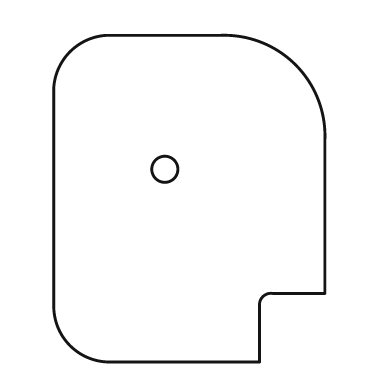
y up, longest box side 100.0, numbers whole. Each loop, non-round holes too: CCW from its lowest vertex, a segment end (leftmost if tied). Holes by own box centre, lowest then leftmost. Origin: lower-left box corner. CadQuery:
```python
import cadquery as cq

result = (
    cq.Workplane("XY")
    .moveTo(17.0, 0.0)
    .lineTo(63.0, 0.0)
    .lineTo(63.0, 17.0)
    .threePointArc((64.0, 20.0), (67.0, 21.0))
    .lineTo(83.0, 21.0)
    .lineTo(83.0, 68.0)
    .threePointArc((74.0, 91.0), (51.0, 100.0))
    .lineTo(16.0, 100.0)
    .threePointArc((5.0, 95.0), (0.0, 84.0))
    .lineTo(0.0, 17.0)
    .threePointArc((5.0, 5.0), (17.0, 0.0))
    .close()
    .moveTo(34.0, 59.0)
    .circle(4.0)
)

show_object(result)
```